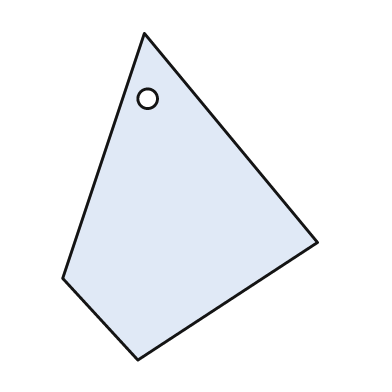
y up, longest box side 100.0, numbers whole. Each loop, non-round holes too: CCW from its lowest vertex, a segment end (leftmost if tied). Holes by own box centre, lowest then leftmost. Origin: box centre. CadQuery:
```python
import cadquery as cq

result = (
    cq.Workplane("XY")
    .moveTo(-16.0, -50.0)
    .lineTo(39.0, -14.0)
    .lineTo(-14.0, 50.0)
    .lineTo(-39.0, -25.0)
    .close()
    .moveTo(-13.0, 30.0)
    .circle(3.0)
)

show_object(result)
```